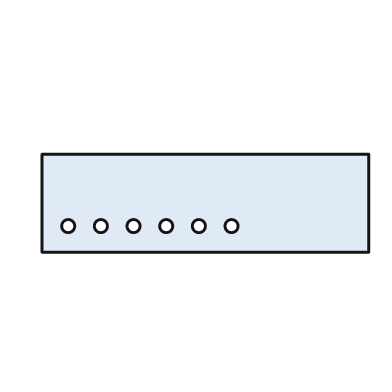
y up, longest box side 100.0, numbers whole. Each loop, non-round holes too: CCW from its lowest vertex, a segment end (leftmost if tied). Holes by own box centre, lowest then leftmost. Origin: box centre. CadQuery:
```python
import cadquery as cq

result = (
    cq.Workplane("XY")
    .moveTo(-50.0, -15.0)
    .lineTo(50.0, -15.0)
    .lineTo(50.0, 15.0)
    .lineTo(-50.0, 15.0)
    .close()
    .moveTo(-42.0, -7.0)
    .circle(2.0)
    .moveTo(-32.0, -7.0)
    .circle(2.0)
    .moveTo(-22.0, -7.0)
    .circle(2.0)
    .moveTo(-12.0, -7.0)
    .circle(2.0)
    .moveTo(-2.0, -7.0)
    .circle(2.0)
    .moveTo(8.0, -7.0)
    .circle(2.0)
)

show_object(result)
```